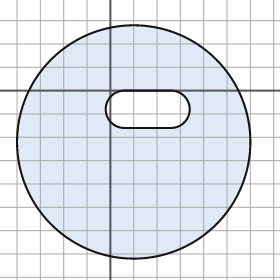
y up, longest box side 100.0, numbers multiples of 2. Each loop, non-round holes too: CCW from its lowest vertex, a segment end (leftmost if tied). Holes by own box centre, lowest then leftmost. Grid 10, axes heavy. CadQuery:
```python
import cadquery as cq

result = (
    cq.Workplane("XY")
    .moveTo(10.0, -22.0)
    .circle(50.0)
    .moveTo(6.0, -16.0)
    .lineTo(26.0, -16.0)
    .threePointArc((34.0, -8.0), (26.0, 0.0))
    .lineTo(6.0, 0.0)
    .threePointArc((-2.0, -8.0), (6.0, -16.0))
    .close()
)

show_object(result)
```